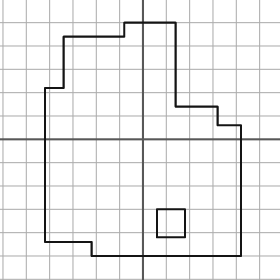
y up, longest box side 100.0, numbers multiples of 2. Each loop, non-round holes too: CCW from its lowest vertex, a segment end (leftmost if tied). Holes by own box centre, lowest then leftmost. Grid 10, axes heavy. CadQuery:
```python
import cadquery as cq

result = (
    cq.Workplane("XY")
    .moveTo(-22.0, -50.0)
    .lineTo(42.0, -50.0)
    .lineTo(42.0, 6.0)
    .lineTo(32.0, 6.0)
    .lineTo(32.0, 14.0)
    .lineTo(14.0, 14.0)
    .lineTo(14.0, 50.0)
    .lineTo(-8.0, 50.0)
    .lineTo(-8.0, 44.0)
    .lineTo(-34.0, 44.0)
    .lineTo(-34.0, 22.0)
    .lineTo(-42.0, 22.0)
    .lineTo(-42.0, -44.0)
    .lineTo(-22.0, -44.0)
    .close()
    .moveTo(6.0, -42.0)
    .lineTo(18.0, -42.0)
    .lineTo(18.0, -30.0)
    .lineTo(6.0, -30.0)
    .close()
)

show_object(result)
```